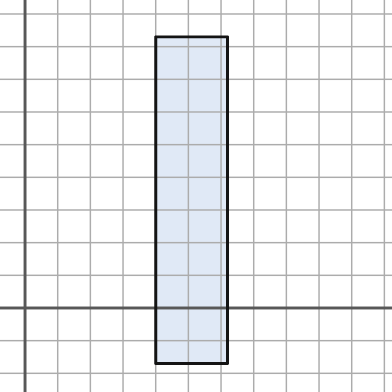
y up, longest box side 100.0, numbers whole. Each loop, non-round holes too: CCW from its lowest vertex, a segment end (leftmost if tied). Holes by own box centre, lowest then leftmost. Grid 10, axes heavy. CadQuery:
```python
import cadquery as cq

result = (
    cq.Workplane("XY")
    .moveTo(40.0, -17.0)
    .lineTo(62.0, -17.0)
    .lineTo(62.0, 83.0)
    .lineTo(40.0, 83.0)
    .close()
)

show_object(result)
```